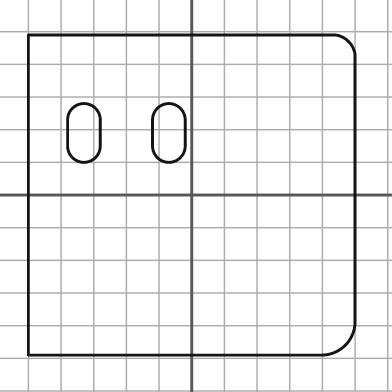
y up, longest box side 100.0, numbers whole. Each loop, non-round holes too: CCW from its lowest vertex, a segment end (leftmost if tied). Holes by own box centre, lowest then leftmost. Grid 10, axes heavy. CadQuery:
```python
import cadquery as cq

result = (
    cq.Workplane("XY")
    .moveTo(-50.0, -49.0)
    .lineTo(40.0, -49.0)
    .threePointArc((47.0, -46.0), (50.0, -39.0))
    .lineTo(50.0, 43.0)
    .threePointArc((48.0, 47.0), (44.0, 49.0))
    .lineTo(-50.0, 49.0)
    .close()
    .moveTo(-38.0, 15.0)
    .threePointArc((-33.0, 10.0), (-28.0, 15.0))
    .lineTo(-28.0, 23.0)
    .threePointArc((-33.0, 28.0), (-38.0, 23.0))
    .close()
    .moveTo(-12.0, 15.0)
    .threePointArc((-7.0, 10.0), (-2.0, 15.0))
    .lineTo(-2.0, 23.0)
    .threePointArc((-7.0, 28.0), (-12.0, 23.0))
    .close()
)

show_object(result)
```